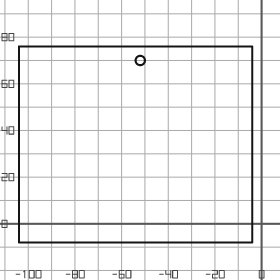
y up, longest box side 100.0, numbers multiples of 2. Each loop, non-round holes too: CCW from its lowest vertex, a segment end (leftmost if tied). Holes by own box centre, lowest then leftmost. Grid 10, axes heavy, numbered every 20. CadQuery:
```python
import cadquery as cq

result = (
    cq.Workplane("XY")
    .moveTo(-104.0, -8.0)
    .lineTo(-4.0, -8.0)
    .lineTo(-4.0, 76.0)
    .lineTo(-104.0, 76.0)
    .close()
    .moveTo(-52.0, 70.0)
    .circle(2.0)
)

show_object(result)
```